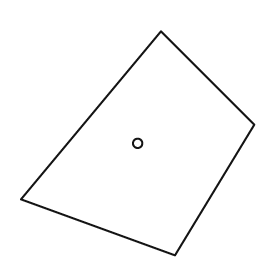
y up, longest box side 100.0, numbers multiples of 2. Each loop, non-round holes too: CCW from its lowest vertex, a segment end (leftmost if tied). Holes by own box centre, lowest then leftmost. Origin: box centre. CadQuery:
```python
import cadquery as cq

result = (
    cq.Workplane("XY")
    .moveTo(16.0, -48.0)
    .lineTo(50.0, 8.0)
    .lineTo(10.0, 48.0)
    .lineTo(-50.0, -24.0)
    .close()
    .moveTo(0.0, 0.0)
    .circle(2.0)
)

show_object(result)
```